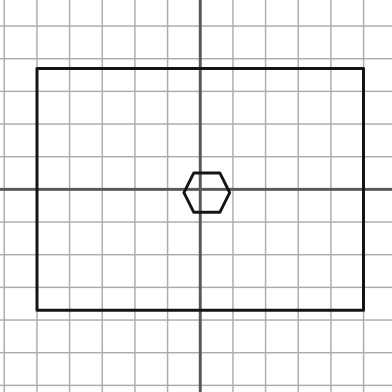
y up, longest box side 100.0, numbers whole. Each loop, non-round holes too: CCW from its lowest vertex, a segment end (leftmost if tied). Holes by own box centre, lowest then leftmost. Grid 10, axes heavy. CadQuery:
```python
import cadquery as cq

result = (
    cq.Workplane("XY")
    .moveTo(-50.0, -37.0)
    .lineTo(50.0, -37.0)
    .lineTo(50.0, 37.0)
    .lineTo(-50.0, 37.0)
    .close()
    .moveTo(-2.0, -7.0)
    .lineTo(6.0, -7.0)
    .lineTo(9.0, -1.0)
    .lineTo(6.0, 5.0)
    .lineTo(-2.0, 5.0)
    .lineTo(-5.0, -1.0)
    .close()
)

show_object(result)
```